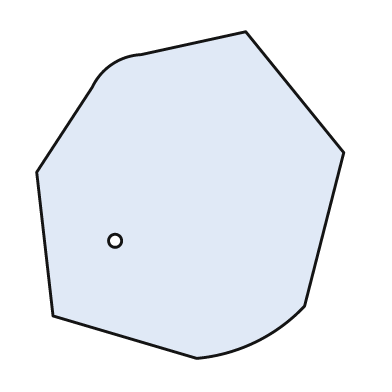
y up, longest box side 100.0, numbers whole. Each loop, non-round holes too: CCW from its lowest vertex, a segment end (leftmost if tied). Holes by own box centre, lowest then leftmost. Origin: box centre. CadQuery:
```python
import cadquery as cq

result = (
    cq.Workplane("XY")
    .moveTo(2.0, -50.0)
    .threePointArc((20.0, -45.0), (35.0, -34.0))
    .lineTo(47.0, 13.0)
    .lineTo(17.0, 50.0)
    .lineTo(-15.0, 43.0)
    .threePointArc((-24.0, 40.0), (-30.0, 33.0))
    .lineTo(-47.0, 7.0)
    .lineTo(-42.0, -37.0)
    .close()
    .moveTo(-23.0, -14.0)
    .circle(2.0)
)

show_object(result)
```